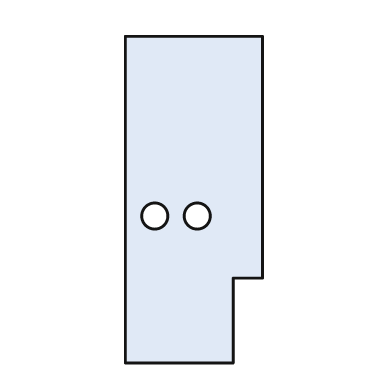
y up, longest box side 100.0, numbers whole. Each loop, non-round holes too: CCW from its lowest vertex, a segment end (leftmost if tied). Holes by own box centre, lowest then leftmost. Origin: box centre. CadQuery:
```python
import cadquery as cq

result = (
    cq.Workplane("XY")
    .moveTo(-21.0, -50.0)
    .lineTo(12.0, -50.0)
    .lineTo(12.0, -24.0)
    .lineTo(21.0, -24.0)
    .lineTo(21.0, 50.0)
    .lineTo(-21.0, 50.0)
    .close()
    .moveTo(-12.0, -5.0)
    .circle(4.0)
    .moveTo(1.0, -5.0)
    .circle(4.0)
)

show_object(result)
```